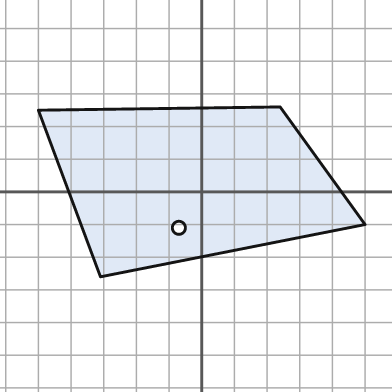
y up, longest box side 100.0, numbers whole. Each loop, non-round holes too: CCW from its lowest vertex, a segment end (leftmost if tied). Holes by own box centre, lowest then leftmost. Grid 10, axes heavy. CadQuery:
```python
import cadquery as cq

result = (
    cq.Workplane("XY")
    .moveTo(-31.0, -26.0)
    .lineTo(50.0, -10.0)
    .lineTo(24.0, 26.0)
    .lineTo(-50.0, 25.0)
    .close()
    .moveTo(-7.0, -11.0)
    .circle(2.0)
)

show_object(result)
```